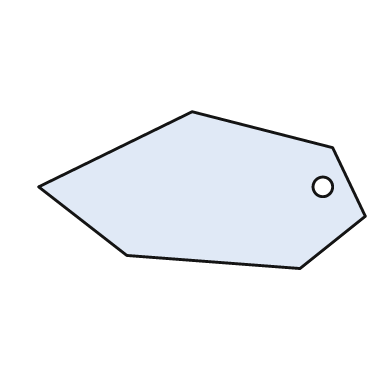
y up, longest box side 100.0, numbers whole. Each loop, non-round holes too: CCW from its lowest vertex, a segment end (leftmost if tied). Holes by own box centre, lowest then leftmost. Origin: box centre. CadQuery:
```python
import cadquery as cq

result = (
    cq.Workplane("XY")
    .moveTo(30.0, -24.0)
    .lineTo(50.0, -8.0)
    .lineTo(40.0, 13.0)
    .lineTo(-3.0, 24.0)
    .lineTo(-50.0, 1.0)
    .lineTo(-23.0, -20.0)
    .close()
    .moveTo(37.0, 1.0)
    .circle(3.0)
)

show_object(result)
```